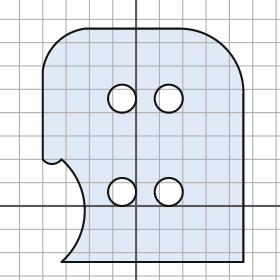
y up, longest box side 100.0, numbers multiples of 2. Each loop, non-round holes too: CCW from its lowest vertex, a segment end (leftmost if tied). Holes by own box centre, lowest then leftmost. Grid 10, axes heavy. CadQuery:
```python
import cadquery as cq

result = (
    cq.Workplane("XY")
    .moveTo(-32.0, -24.0)
    .lineTo(46.0, -24.0)
    .lineTo(46.0, 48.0)
    .threePointArc((38.0, 68.0), (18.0, 76.0))
    .lineTo(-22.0, 76.0)
    .threePointArc((-34.0, 70.0), (-40.0, 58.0))
    .lineTo(-40.0, 20.0)
    .threePointArc((-36.0, 18.0), (-32.0, 20.0))
    .threePointArc((-22.0, -2.0), (-32.0, -24.0))
    .close()
    .moveTo(-6.0, 6.0)
    .circle(6.0)
    .moveTo(14.0, 6.0)
    .circle(6.0)
    .moveTo(-6.0, 46.0)
    .circle(6.0)
    .moveTo(14.0, 46.0)
    .circle(6.0)
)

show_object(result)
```